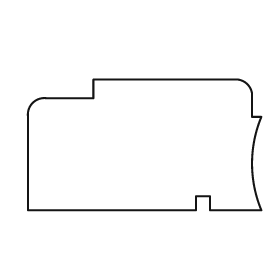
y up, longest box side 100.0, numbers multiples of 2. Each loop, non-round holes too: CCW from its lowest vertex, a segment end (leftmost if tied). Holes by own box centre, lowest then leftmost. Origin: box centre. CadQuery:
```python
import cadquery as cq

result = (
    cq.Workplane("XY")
    .moveTo(-50.0, -28.0)
    .lineTo(22.0, -28.0)
    .lineTo(22.0, -22.0)
    .lineTo(28.0, -22.0)
    .lineTo(28.0, -28.0)
    .lineTo(50.0, -28.0)
    .threePointArc((46.0, -8.0), (50.0, 12.0))
    .lineTo(46.0, 12.0)
    .lineTo(46.0, 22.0)
    .threePointArc((44.0, 26.0), (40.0, 28.0))
    .lineTo(-22.0, 28.0)
    .lineTo(-22.0, 20.0)
    .lineTo(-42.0, 20.0)
    .threePointArc((-48.0, 18.0), (-50.0, 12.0))
    .close()
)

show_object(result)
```